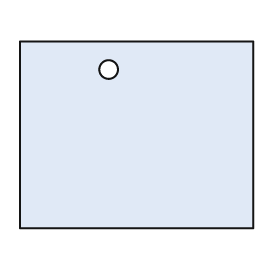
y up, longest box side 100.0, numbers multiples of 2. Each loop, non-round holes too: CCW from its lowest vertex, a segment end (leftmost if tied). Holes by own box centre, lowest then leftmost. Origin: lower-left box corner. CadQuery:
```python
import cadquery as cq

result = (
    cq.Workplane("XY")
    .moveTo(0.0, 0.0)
    .lineTo(100.0, 0.0)
    .lineTo(100.0, 80.0)
    .lineTo(0.0, 80.0)
    .close()
    .moveTo(38.0, 68.0)
    .circle(4.0)
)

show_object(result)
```